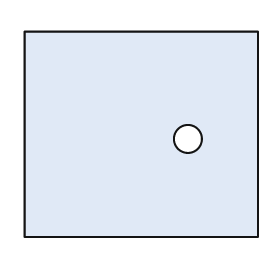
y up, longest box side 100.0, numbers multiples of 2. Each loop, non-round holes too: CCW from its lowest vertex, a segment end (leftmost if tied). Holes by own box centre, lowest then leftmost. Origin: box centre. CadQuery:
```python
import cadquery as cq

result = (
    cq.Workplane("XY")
    .moveTo(-50.0, -44.0)
    .lineTo(50.0, -44.0)
    .lineTo(50.0, 44.0)
    .lineTo(-50.0, 44.0)
    .close()
    .moveTo(20.0, -2.0)
    .circle(6.0)
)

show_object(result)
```